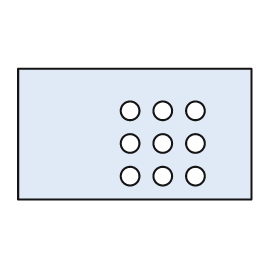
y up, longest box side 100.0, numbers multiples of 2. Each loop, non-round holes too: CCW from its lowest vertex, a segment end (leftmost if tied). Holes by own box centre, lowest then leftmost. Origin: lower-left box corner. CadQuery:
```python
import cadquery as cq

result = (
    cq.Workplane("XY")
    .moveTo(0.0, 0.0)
    .lineTo(100.0, 0.0)
    .lineTo(100.0, 56.0)
    .lineTo(0.0, 56.0)
    .close()
    .moveTo(48.0, 10.0)
    .circle(4.0)
    .moveTo(62.0, 10.0)
    .circle(4.0)
    .moveTo(76.0, 10.0)
    .circle(4.0)
    .moveTo(48.0, 24.0)
    .circle(4.0)
    .moveTo(62.0, 24.0)
    .circle(4.0)
    .moveTo(76.0, 24.0)
    .circle(4.0)
    .moveTo(48.0, 38.0)
    .circle(4.0)
    .moveTo(62.0, 38.0)
    .circle(4.0)
    .moveTo(76.0, 38.0)
    .circle(4.0)
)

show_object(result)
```